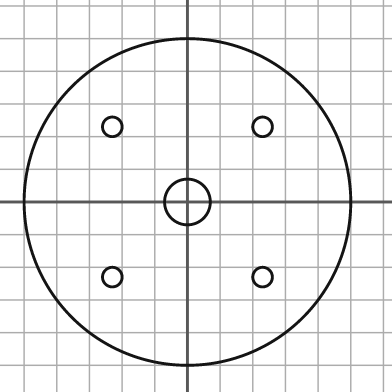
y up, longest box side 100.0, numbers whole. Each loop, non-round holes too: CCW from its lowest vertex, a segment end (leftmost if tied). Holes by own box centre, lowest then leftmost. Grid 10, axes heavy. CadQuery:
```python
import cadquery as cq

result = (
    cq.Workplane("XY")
    .moveTo(0.0, 0.0)
    .circle(50.0)
    .moveTo(-23.0, -23.0)
    .circle(3.0)
    .moveTo(23.0, -23.0)
    .circle(3.0)
    .moveTo(0.0, 0.0)
    .circle(7.0)
    .moveTo(-23.0, 23.0)
    .circle(3.0)
    .moveTo(23.0, 23.0)
    .circle(3.0)
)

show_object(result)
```